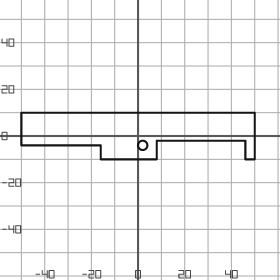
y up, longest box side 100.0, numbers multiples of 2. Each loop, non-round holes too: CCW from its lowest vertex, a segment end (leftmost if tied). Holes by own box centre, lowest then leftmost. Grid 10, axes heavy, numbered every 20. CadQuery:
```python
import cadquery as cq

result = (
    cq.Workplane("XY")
    .moveTo(-16.0, -10.0)
    .lineTo(8.0, -10.0)
    .lineTo(8.0, -2.0)
    .lineTo(46.0, -2.0)
    .lineTo(46.0, -10.0)
    .lineTo(50.0, -10.0)
    .lineTo(50.0, 10.0)
    .lineTo(-50.0, 10.0)
    .lineTo(-50.0, -4.0)
    .lineTo(-16.0, -4.0)
    .close()
    .moveTo(2.0, -4.0)
    .circle(2.0)
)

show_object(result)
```